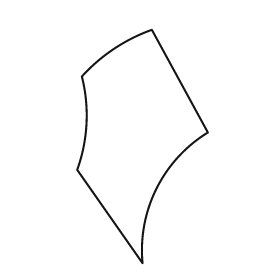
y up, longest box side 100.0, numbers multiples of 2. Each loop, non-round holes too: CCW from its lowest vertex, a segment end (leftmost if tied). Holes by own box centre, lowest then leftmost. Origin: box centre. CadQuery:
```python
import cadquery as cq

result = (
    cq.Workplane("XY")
    .moveTo(0.0, -50.0)
    .threePointArc((6.0, -18.0), (28.0, 6.0))
    .lineTo(4.0, 50.0)
    .threePointArc((-12.0, 42.0), (-26.0, 30.0))
    .threePointArc((-24.0, 10.0), (-28.0, -10.0))
    .close()
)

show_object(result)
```